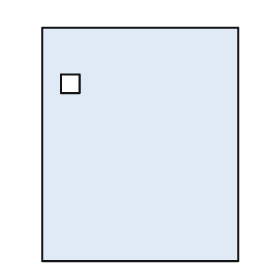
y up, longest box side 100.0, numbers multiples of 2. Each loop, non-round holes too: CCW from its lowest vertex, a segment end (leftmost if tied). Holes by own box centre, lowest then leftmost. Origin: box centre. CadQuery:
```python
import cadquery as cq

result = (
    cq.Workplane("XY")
    .moveTo(-42.0, -50.0)
    .lineTo(42.0, -50.0)
    .lineTo(42.0, 50.0)
    .lineTo(-42.0, 50.0)
    .close()
    .moveTo(-34.0, 22.0)
    .lineTo(-26.0, 22.0)
    .lineTo(-26.0, 30.0)
    .lineTo(-34.0, 30.0)
    .close()
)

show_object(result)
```